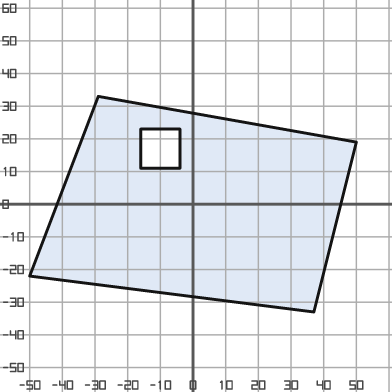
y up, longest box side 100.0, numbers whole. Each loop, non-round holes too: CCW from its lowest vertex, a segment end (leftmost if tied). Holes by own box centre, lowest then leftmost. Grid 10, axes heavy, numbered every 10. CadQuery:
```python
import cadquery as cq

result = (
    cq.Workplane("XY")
    .moveTo(37.0, -33.0)
    .lineTo(50.0, 19.0)
    .lineTo(-29.0, 33.0)
    .lineTo(-50.0, -22.0)
    .close()
    .moveTo(-16.0, 11.0)
    .lineTo(-4.0, 11.0)
    .lineTo(-4.0, 23.0)
    .lineTo(-16.0, 23.0)
    .close()
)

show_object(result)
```